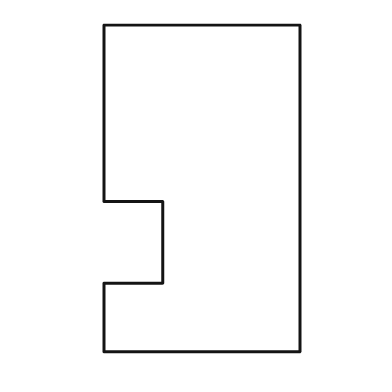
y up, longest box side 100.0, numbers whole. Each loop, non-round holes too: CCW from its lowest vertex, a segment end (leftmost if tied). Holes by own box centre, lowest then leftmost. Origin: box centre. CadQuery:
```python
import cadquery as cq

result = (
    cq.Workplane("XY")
    .moveTo(-30.0, -50.0)
    .lineTo(30.0, -50.0)
    .lineTo(30.0, 50.0)
    .lineTo(-30.0, 50.0)
    .lineTo(-30.0, -4.0)
    .lineTo(-12.0, -4.0)
    .lineTo(-12.0, -29.0)
    .lineTo(-30.0, -29.0)
    .close()
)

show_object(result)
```